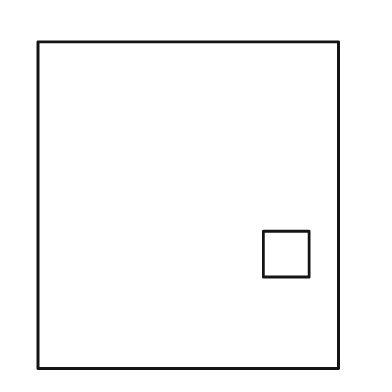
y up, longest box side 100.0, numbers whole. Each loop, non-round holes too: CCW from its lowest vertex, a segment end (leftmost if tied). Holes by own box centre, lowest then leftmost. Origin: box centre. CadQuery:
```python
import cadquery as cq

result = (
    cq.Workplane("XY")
    .moveTo(-46.0, -50.0)
    .lineTo(46.0, -50.0)
    .lineTo(46.0, 50.0)
    .lineTo(-46.0, 50.0)
    .close()
    .moveTo(23.0, -22.0)
    .lineTo(37.0, -22.0)
    .lineTo(37.0, -8.0)
    .lineTo(23.0, -8.0)
    .close()
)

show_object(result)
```